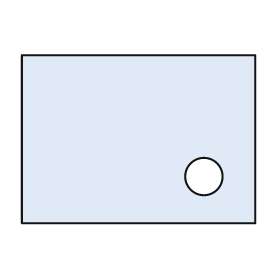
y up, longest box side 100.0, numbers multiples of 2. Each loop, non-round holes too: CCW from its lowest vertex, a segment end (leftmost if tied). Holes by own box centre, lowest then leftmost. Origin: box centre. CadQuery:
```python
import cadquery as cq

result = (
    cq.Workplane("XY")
    .moveTo(-50.0, -36.0)
    .lineTo(50.0, -36.0)
    .lineTo(50.0, 36.0)
    .lineTo(-50.0, 36.0)
    .close()
    .moveTo(28.0, -16.0)
    .circle(8.0)
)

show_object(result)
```